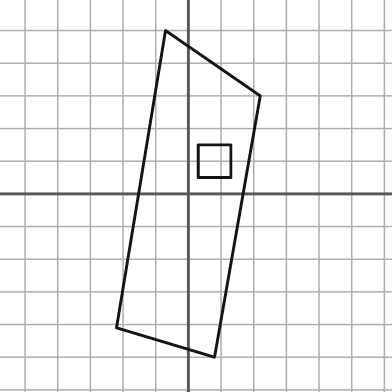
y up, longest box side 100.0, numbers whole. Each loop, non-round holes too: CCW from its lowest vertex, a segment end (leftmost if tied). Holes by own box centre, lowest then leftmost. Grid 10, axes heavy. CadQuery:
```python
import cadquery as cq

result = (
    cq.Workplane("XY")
    .moveTo(8.0, -50.0)
    .lineTo(22.0, 30.0)
    .lineTo(-7.0, 50.0)
    .lineTo(-22.0, -41.0)
    .close()
    .moveTo(3.0, 5.0)
    .lineTo(13.0, 5.0)
    .lineTo(13.0, 15.0)
    .lineTo(3.0, 15.0)
    .close()
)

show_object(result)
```